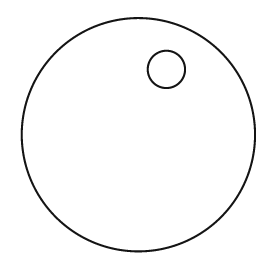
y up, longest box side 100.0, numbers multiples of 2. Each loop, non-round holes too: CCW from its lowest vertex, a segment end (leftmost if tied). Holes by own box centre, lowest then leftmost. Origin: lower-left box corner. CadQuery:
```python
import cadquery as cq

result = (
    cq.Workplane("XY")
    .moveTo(50.0, 50.0)
    .circle(50.0)
    .moveTo(62.0, 78.0)
    .circle(8.0)
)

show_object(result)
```